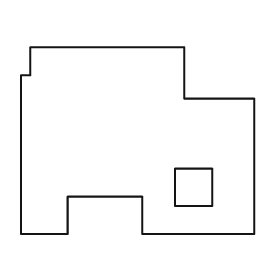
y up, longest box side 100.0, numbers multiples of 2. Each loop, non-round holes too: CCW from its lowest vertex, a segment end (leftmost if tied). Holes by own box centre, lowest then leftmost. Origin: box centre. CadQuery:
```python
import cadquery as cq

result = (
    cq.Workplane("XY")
    .moveTo(-50.0, -40.0)
    .lineTo(-30.0, -40.0)
    .lineTo(-30.0, -24.0)
    .lineTo(2.0, -24.0)
    .lineTo(2.0, -40.0)
    .lineTo(50.0, -40.0)
    .lineTo(50.0, 18.0)
    .lineTo(20.0, 18.0)
    .lineTo(20.0, 40.0)
    .lineTo(-46.0, 40.0)
    .lineTo(-46.0, 28.0)
    .lineTo(-50.0, 28.0)
    .close()
    .moveTo(16.0, -28.0)
    .lineTo(32.0, -28.0)
    .lineTo(32.0, -12.0)
    .lineTo(16.0, -12.0)
    .close()
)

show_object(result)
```